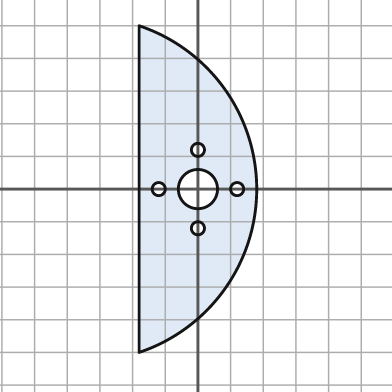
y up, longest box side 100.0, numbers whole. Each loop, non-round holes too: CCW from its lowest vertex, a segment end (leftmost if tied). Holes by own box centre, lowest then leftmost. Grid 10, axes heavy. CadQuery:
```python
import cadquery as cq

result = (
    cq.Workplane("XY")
    .moveTo(-18.0, -50.0)
    .threePointArc((18.0, 0.0), (-18.0, 50.0))
    .close()
    .moveTo(0.0, -12.0)
    .circle(2.0)
    .moveTo(-12.0, 0.0)
    .circle(2.0)
    .moveTo(0.0, 0.0)
    .circle(6.0)
    .moveTo(12.0, 0.0)
    .circle(2.0)
    .moveTo(0.0, 12.0)
    .circle(2.0)
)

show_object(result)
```